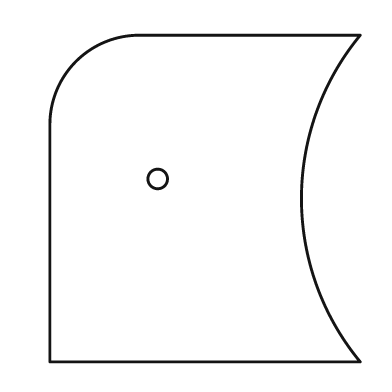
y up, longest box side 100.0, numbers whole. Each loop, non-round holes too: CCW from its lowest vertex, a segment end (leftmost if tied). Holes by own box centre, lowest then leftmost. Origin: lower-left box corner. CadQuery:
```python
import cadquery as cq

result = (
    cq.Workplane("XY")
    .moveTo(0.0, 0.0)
    .lineTo(95.0, 0.0)
    .threePointArc((77.0, 50.0), (95.0, 100.0))
    .lineTo(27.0, 100.0)
    .threePointArc((8.0, 92.0), (0.0, 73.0))
    .close()
    .moveTo(33.0, 56.0)
    .circle(3.0)
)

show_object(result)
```